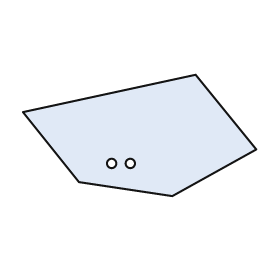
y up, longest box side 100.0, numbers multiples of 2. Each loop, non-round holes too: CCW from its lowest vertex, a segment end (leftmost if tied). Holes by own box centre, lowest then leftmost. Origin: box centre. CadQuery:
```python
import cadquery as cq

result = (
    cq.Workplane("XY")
    .moveTo(14.0, -26.0)
    .lineTo(50.0, -6.0)
    .lineTo(24.0, 26.0)
    .lineTo(-50.0, 10.0)
    .lineTo(-26.0, -20.0)
    .close()
    .moveTo(-12.0, -12.0)
    .circle(2.0)
    .moveTo(-4.0, -12.0)
    .circle(2.0)
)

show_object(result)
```